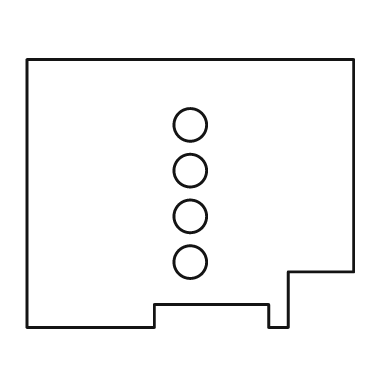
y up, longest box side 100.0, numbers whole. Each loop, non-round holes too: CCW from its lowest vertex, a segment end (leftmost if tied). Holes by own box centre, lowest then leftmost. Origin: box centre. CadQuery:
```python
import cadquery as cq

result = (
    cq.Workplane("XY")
    .moveTo(-50.0, -41.0)
    .lineTo(-11.0, -41.0)
    .lineTo(-11.0, -34.0)
    .lineTo(24.0, -34.0)
    .lineTo(24.0, -41.0)
    .lineTo(30.0, -41.0)
    .lineTo(30.0, -24.0)
    .lineTo(50.0, -24.0)
    .lineTo(50.0, 41.0)
    .lineTo(-50.0, 41.0)
    .close()
    .moveTo(0.0, -21.0)
    .circle(5.0)
    .moveTo(0.0, -7.0)
    .circle(5.0)
    .moveTo(0.0, 7.0)
    .circle(5.0)
    .moveTo(0.0, 21.0)
    .circle(5.0)
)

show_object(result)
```